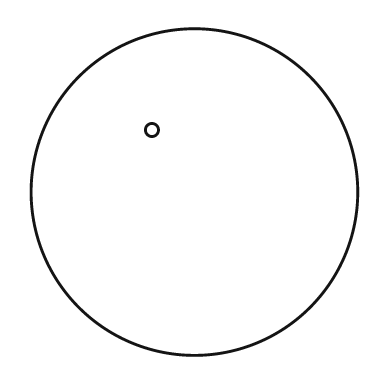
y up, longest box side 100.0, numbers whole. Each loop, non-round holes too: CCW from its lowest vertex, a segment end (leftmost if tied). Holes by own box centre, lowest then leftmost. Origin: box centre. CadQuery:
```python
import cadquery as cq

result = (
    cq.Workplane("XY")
    .moveTo(0.0, 0.0)
    .circle(50.0)
    .moveTo(-13.0, 19.0)
    .circle(2.0)
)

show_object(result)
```